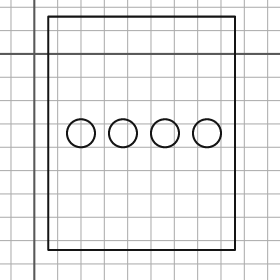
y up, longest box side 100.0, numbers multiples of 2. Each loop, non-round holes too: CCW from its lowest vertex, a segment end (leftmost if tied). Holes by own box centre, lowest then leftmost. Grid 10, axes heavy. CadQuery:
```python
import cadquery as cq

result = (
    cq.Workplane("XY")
    .moveTo(6.0, -84.0)
    .lineTo(86.0, -84.0)
    .lineTo(86.0, 16.0)
    .lineTo(6.0, 16.0)
    .close()
    .moveTo(20.0, -34.0)
    .circle(6.0)
    .moveTo(38.0, -34.0)
    .circle(6.0)
    .moveTo(56.0, -34.0)
    .circle(6.0)
    .moveTo(74.0, -34.0)
    .circle(6.0)
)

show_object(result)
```